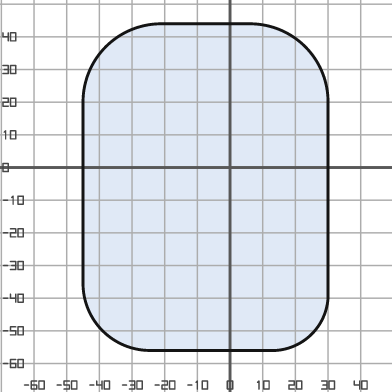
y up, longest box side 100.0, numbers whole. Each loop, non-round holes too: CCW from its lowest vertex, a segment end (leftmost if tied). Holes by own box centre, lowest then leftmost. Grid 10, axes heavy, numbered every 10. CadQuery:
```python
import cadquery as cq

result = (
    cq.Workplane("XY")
    .moveTo(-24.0, -56.0)
    .lineTo(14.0, -56.0)
    .threePointArc((25.0, -51.0), (30.0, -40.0))
    .lineTo(30.0, 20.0)
    .threePointArc((23.0, 37.0), (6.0, 44.0))
    .lineTo(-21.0, 44.0)
    .threePointArc((-38.0, 37.0), (-45.0, 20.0))
    .lineTo(-45.0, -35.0)
    .threePointArc((-39.0, -50.0), (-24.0, -56.0))
    .close()
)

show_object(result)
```